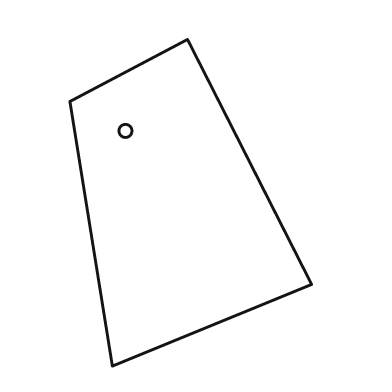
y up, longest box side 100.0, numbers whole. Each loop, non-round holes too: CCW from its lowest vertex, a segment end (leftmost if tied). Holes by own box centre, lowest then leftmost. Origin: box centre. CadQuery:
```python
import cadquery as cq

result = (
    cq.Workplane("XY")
    .moveTo(-24.0, -50.0)
    .lineTo(37.0, -25.0)
    .lineTo(-1.0, 50.0)
    .lineTo(-37.0, 31.0)
    .close()
    .moveTo(-20.0, 22.0)
    .circle(2.0)
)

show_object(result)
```